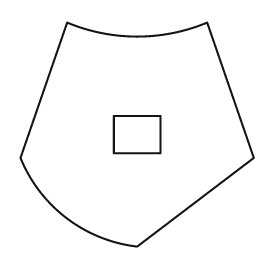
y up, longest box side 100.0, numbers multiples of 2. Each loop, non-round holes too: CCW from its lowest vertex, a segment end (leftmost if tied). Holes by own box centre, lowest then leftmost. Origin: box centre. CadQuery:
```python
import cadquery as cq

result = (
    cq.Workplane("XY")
    .moveTo(0.0, -48.0)
    .lineTo(50.0, -10.0)
    .lineTo(30.0, 48.0)
    .threePointArc((0.0, 42.0), (-30.0, 48.0))
    .lineTo(-50.0, -10.0)
    .threePointArc((-30.0, -36.0), (0.0, -48.0))
    .close()
    .moveTo(-10.0, -8.0)
    .lineTo(10.0, -8.0)
    .lineTo(10.0, 8.0)
    .lineTo(-10.0, 8.0)
    .close()
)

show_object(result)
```